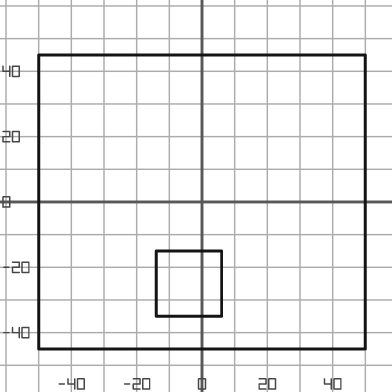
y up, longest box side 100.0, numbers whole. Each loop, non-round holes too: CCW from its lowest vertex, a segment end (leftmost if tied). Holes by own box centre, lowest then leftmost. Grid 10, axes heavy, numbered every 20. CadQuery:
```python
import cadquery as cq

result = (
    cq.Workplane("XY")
    .moveTo(-50.0, -45.0)
    .lineTo(50.0, -45.0)
    .lineTo(50.0, 45.0)
    .lineTo(-50.0, 45.0)
    .close()
    .moveTo(-14.0, -35.0)
    .lineTo(6.0, -35.0)
    .lineTo(6.0, -15.0)
    .lineTo(-14.0, -15.0)
    .close()
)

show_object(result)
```